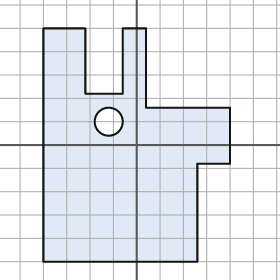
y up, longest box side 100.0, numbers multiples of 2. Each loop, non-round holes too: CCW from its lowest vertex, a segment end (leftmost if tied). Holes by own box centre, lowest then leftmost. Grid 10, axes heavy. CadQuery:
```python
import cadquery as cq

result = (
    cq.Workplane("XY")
    .moveTo(-40.0, -50.0)
    .lineTo(26.0, -50.0)
    .lineTo(26.0, -8.0)
    .lineTo(40.0, -8.0)
    .lineTo(40.0, 16.0)
    .lineTo(4.0, 16.0)
    .lineTo(4.0, 50.0)
    .lineTo(-6.0, 50.0)
    .lineTo(-6.0, 22.0)
    .lineTo(-22.0, 22.0)
    .lineTo(-22.0, 50.0)
    .lineTo(-40.0, 50.0)
    .close()
    .moveTo(-12.0, 10.0)
    .circle(6.0)
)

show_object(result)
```